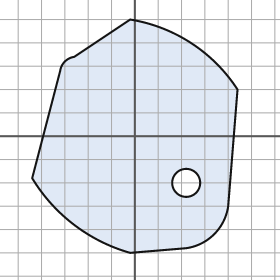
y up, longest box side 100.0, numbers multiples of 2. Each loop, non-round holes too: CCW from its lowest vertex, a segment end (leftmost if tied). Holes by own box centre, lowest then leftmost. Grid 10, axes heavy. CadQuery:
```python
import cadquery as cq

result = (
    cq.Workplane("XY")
    .moveTo(-2.0, -50.0)
    .lineTo(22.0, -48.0)
    .threePointArc((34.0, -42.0), (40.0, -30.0))
    .lineTo(44.0, 20.0)
    .threePointArc((24.0, 40.0), (-2.0, 50.0))
    .lineTo(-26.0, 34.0)
    .threePointArc((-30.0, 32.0), (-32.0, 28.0))
    .lineTo(-44.0, -18.0)
    .threePointArc((-26.0, -38.0), (-2.0, -50.0))
    .close()
    .moveTo(22.0, -20.0)
    .circle(6.0)
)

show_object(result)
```